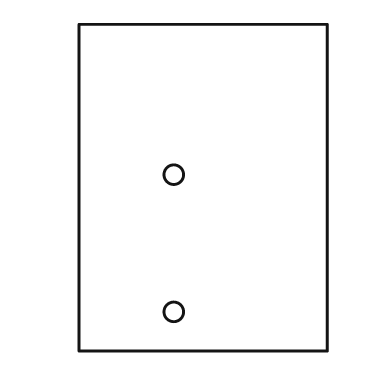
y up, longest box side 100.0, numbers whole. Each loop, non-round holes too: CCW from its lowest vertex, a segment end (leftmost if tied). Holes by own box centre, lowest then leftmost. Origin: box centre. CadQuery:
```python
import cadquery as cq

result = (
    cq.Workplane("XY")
    .moveTo(-38.0, -50.0)
    .lineTo(38.0, -50.0)
    .lineTo(38.0, 50.0)
    .lineTo(-38.0, 50.0)
    .close()
    .moveTo(-9.0, -38.0)
    .circle(3.0)
    .moveTo(-9.0, 4.0)
    .circle(3.0)
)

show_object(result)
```